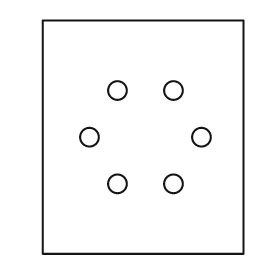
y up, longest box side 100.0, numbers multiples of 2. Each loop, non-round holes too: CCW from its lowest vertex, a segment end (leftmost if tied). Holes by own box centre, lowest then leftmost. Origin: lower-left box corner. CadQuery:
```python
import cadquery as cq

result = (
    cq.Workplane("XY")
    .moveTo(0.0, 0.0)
    .lineTo(86.0, 0.0)
    .lineTo(86.0, 100.0)
    .lineTo(0.0, 100.0)
    .close()
    .moveTo(32.0, 30.0)
    .circle(4.0)
    .moveTo(56.0, 30.0)
    .circle(4.0)
    .moveTo(20.0, 50.0)
    .circle(4.0)
    .moveTo(68.0, 50.0)
    .circle(4.0)
    .moveTo(32.0, 70.0)
    .circle(4.0)
    .moveTo(56.0, 70.0)
    .circle(4.0)
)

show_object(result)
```